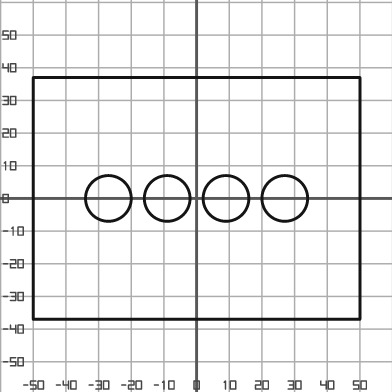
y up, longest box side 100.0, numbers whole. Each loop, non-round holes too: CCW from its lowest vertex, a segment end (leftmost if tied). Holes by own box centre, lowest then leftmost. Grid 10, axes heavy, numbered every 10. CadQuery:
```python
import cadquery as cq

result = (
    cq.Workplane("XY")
    .moveTo(-50.0, -37.0)
    .lineTo(50.0, -37.0)
    .lineTo(50.0, 37.0)
    .lineTo(-50.0, 37.0)
    .close()
    .moveTo(-27.0, 0.0)
    .circle(7.0)
    .moveTo(-9.0, 0.0)
    .circle(7.0)
    .moveTo(9.0, 0.0)
    .circle(7.0)
    .moveTo(27.0, 0.0)
    .circle(7.0)
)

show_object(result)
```